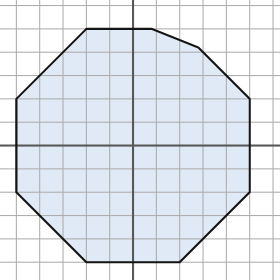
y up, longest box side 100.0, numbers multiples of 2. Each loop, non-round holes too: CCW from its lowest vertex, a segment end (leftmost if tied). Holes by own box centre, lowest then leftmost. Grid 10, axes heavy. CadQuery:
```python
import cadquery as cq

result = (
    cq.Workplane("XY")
    .moveTo(-20.0, -50.0)
    .lineTo(20.0, -50.0)
    .lineTo(50.0, -20.0)
    .lineTo(50.0, 20.0)
    .lineTo(28.0, 42.0)
    .lineTo(8.0, 50.0)
    .lineTo(-20.0, 50.0)
    .lineTo(-50.0, 20.0)
    .lineTo(-50.0, -20.0)
    .close()
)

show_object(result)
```